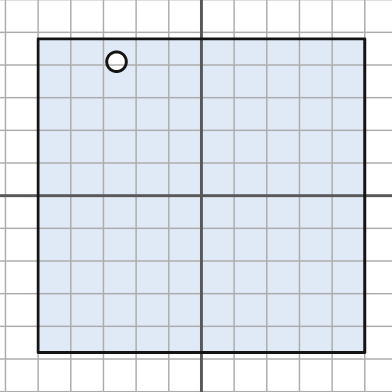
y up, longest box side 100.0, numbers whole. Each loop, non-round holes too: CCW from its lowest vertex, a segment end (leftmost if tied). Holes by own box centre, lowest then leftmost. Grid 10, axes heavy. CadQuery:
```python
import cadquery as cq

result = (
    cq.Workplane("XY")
    .moveTo(-50.0, -48.0)
    .lineTo(50.0, -48.0)
    .lineTo(50.0, 48.0)
    .lineTo(-50.0, 48.0)
    .close()
    .moveTo(-26.0, 41.0)
    .circle(3.0)
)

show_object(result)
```